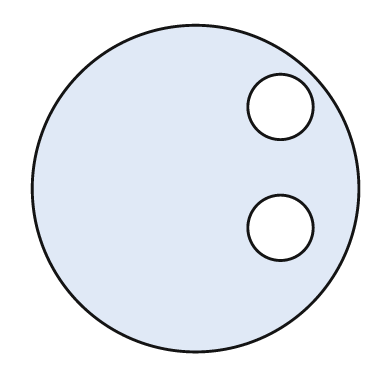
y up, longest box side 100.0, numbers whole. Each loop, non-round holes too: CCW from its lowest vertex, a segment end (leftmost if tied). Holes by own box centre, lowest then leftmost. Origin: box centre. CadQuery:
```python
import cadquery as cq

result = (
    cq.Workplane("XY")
    .moveTo(0.0, 0.0)
    .circle(50.0)
    .moveTo(26.0, -12.0)
    .circle(10.0)
    .moveTo(26.0, 25.0)
    .circle(10.0)
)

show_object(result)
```